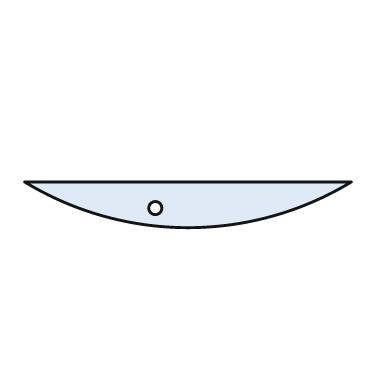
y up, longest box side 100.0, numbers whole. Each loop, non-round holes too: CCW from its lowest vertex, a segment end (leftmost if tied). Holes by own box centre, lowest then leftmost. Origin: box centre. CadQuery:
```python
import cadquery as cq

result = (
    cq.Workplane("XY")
    .moveTo(-50.0, 7.0)
    .threePointArc((0.0, -7.0), (50.0, 7.0))
    .close()
    .moveTo(-10.0, -1.0)
    .circle(2.0)
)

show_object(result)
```